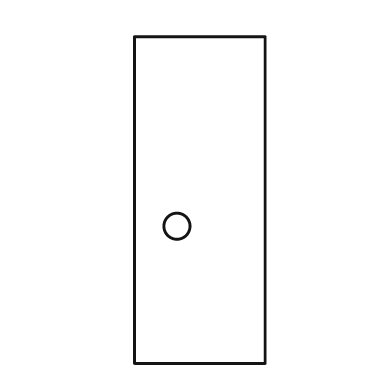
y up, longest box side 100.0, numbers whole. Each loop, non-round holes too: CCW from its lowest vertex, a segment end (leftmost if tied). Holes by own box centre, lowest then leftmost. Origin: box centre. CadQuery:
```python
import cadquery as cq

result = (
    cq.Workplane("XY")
    .moveTo(-20.0, -50.0)
    .lineTo(20.0, -50.0)
    .lineTo(20.0, 50.0)
    .lineTo(-20.0, 50.0)
    .close()
    .moveTo(-7.0, -8.0)
    .circle(4.0)
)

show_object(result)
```